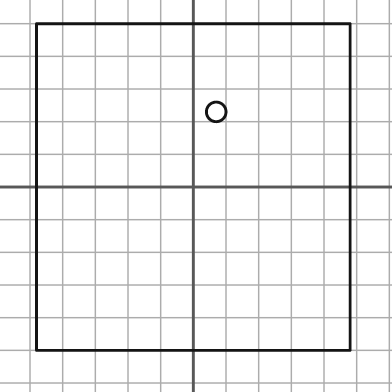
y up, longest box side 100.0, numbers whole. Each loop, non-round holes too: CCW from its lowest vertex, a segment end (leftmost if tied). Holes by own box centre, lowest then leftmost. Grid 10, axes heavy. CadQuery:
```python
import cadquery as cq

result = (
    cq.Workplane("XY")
    .moveTo(-48.0, -50.0)
    .lineTo(48.0, -50.0)
    .lineTo(48.0, 50.0)
    .lineTo(-48.0, 50.0)
    .close()
    .moveTo(7.0, 23.0)
    .circle(3.0)
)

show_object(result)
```